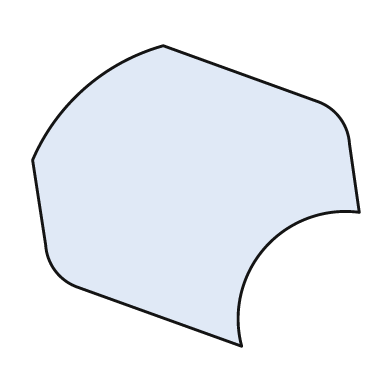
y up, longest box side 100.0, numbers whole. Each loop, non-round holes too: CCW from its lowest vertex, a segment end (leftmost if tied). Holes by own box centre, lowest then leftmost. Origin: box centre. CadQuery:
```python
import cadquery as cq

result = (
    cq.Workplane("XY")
    .moveTo(14.0, -46.0)
    .threePointArc((21.0, -16.0), (50.0, -5.0))
    .lineTo(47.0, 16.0)
    .threePointArc((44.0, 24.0), (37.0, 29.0))
    .lineTo(-10.0, 46.0)
    .threePointArc((-34.0, 33.0), (-50.0, 11.0))
    .lineTo(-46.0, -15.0)
    .threePointArc((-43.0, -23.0), (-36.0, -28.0))
    .close()
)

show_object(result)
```